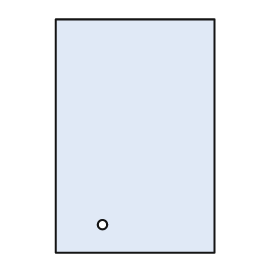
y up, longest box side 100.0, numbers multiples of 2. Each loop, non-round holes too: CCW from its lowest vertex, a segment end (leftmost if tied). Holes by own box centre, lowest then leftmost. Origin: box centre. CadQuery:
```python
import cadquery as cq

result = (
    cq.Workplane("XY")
    .moveTo(-34.0, -50.0)
    .lineTo(34.0, -50.0)
    .lineTo(34.0, 50.0)
    .lineTo(-34.0, 50.0)
    .close()
    .moveTo(-14.0, -38.0)
    .circle(2.0)
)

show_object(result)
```